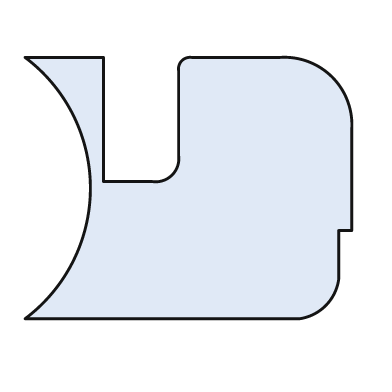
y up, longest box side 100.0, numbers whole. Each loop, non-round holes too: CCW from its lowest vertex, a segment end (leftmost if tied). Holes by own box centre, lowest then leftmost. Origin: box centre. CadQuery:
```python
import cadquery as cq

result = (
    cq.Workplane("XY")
    .moveTo(-50.0, -40.0)
    .lineTo(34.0, -40.0)
    .threePointArc((42.0, -36.0), (46.0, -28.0))
    .lineTo(46.0, -13.0)
    .lineTo(50.0, -13.0)
    .lineTo(50.0, 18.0)
    .threePointArc((44.0, 34.0), (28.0, 40.0))
    .lineTo(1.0, 40.0)
    .threePointArc((-2.0, 39.0), (-3.0, 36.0))
    .lineTo(-3.0, 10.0)
    .threePointArc((-5.0, 4.0), (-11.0, 2.0))
    .lineTo(-26.0, 2.0)
    .lineTo(-26.0, 40.0)
    .lineTo(-50.0, 40.0)
    .threePointArc((-30.0, 0.0), (-50.0, -40.0))
    .close()
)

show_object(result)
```